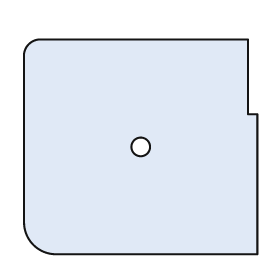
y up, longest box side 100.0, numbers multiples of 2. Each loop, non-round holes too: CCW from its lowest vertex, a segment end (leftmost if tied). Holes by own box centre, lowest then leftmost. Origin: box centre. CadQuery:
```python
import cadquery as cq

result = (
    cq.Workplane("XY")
    .moveTo(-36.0, -46.0)
    .lineTo(50.0, -46.0)
    .lineTo(50.0, 14.0)
    .lineTo(46.0, 14.0)
    .lineTo(46.0, 46.0)
    .lineTo(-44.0, 46.0)
    .threePointArc((-48.0, 44.0), (-50.0, 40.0))
    .lineTo(-50.0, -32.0)
    .threePointArc((-46.0, -42.0), (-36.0, -46.0))
    .close()
    .moveTo(0.0, 0.0)
    .circle(4.0)
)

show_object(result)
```